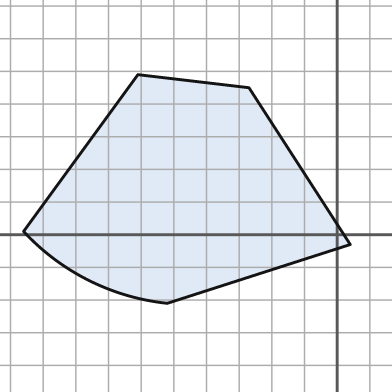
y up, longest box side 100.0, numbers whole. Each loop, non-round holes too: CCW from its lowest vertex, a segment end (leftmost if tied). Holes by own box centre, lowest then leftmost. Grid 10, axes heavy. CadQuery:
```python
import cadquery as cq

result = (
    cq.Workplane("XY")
    .moveTo(-52.0, -21.0)
    .lineTo(4.0, -3.0)
    .lineTo(-27.0, 45.0)
    .lineTo(-61.0, 49.0)
    .lineTo(-96.0, 1.0)
    .threePointArc((-76.0, -14.0), (-52.0, -21.0))
    .close()
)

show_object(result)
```